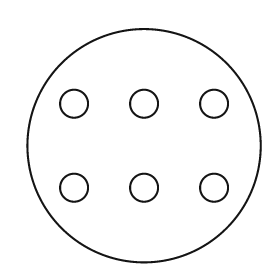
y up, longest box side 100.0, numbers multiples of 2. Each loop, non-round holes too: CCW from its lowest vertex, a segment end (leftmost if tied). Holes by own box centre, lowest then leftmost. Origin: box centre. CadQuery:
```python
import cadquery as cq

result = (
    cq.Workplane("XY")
    .moveTo(0.0, 0.0)
    .circle(50.0)
    .moveTo(-30.0, -18.0)
    .circle(6.0)
    .moveTo(0.0, -18.0)
    .circle(6.0)
    .moveTo(30.0, -18.0)
    .circle(6.0)
    .moveTo(-30.0, 18.0)
    .circle(6.0)
    .moveTo(0.0, 18.0)
    .circle(6.0)
    .moveTo(30.0, 18.0)
    .circle(6.0)
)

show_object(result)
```